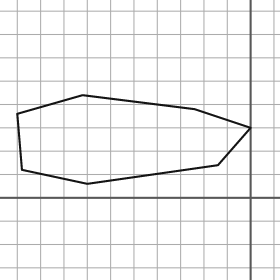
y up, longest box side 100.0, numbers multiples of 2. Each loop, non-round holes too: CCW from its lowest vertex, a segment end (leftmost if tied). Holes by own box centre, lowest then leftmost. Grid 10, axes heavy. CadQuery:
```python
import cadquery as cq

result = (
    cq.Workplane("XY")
    .moveTo(-70.0, 6.0)
    .lineTo(-14.0, 14.0)
    .lineTo(0.0, 30.0)
    .lineTo(-24.0, 38.0)
    .lineTo(-72.0, 44.0)
    .lineTo(-100.0, 36.0)
    .lineTo(-98.0, 12.0)
    .close()
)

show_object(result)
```